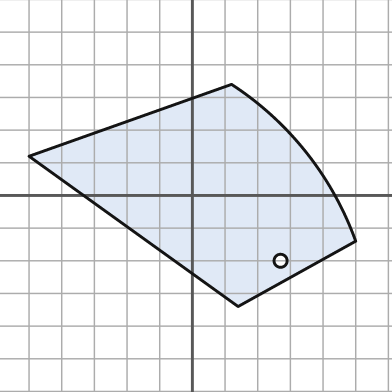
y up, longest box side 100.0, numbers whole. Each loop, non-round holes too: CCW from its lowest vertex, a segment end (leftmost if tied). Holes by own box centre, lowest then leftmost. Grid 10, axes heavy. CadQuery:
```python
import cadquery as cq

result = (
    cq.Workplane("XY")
    .moveTo(14.0, -34.0)
    .lineTo(50.0, -14.0)
    .threePointArc((35.0, 13.0), (12.0, 34.0))
    .lineTo(-50.0, 12.0)
    .close()
    .moveTo(27.0, -20.0)
    .circle(2.0)
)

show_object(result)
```